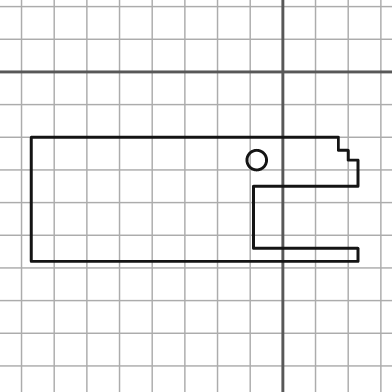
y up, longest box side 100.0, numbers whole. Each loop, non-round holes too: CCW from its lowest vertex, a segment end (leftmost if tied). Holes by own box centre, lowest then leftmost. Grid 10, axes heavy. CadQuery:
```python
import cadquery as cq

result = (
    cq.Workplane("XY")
    .moveTo(-77.0, -58.0)
    .lineTo(23.0, -58.0)
    .lineTo(23.0, -54.0)
    .lineTo(-9.0, -54.0)
    .lineTo(-9.0, -35.0)
    .lineTo(23.0, -35.0)
    .lineTo(23.0, -27.0)
    .lineTo(20.0, -27.0)
    .lineTo(20.0, -24.0)
    .lineTo(17.0, -24.0)
    .lineTo(17.0, -20.0)
    .lineTo(-77.0, -20.0)
    .close()
    .moveTo(-8.0, -27.0)
    .circle(3.0)
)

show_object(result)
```